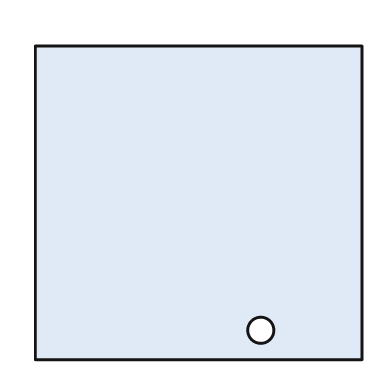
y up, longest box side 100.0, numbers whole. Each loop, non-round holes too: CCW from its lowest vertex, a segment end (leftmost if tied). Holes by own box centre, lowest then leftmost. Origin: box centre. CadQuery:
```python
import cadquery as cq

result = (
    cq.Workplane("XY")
    .moveTo(-50.0, -48.0)
    .lineTo(50.0, -48.0)
    .lineTo(50.0, 48.0)
    .lineTo(-50.0, 48.0)
    .close()
    .moveTo(19.0, -39.0)
    .circle(4.0)
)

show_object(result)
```